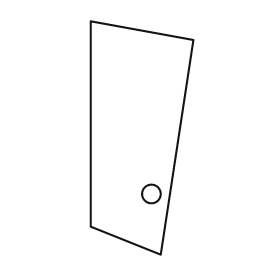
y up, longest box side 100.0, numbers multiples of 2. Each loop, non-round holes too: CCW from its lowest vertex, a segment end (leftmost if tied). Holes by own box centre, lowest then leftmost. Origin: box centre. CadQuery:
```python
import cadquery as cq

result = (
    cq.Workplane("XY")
    .moveTo(8.0, -50.0)
    .lineTo(22.0, 42.0)
    .lineTo(-22.0, 50.0)
    .lineTo(-22.0, -38.0)
    .close()
    .moveTo(4.0, -24.0)
    .circle(4.0)
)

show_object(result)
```